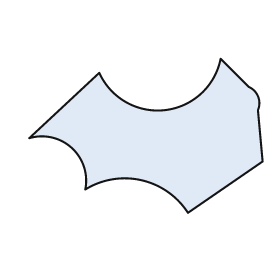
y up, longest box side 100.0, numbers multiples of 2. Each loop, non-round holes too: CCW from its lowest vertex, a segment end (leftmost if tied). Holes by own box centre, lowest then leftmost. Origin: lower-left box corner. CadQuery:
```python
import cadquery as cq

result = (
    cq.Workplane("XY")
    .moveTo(68.0, 0.0)
    .lineTo(100.0, 22.0)
    .lineTo(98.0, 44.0)
    .threePointArc((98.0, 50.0), (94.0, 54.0))
    .lineTo(82.0, 66.0)
    .threePointArc((58.0, 44.0), (30.0, 60.0))
    .lineTo(0.0, 32.0)
    .threePointArc((18.0, 28.0), (24.0, 10.0))
    .threePointArc((48.0, 14.0), (68.0, 0.0))
    .close()
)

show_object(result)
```